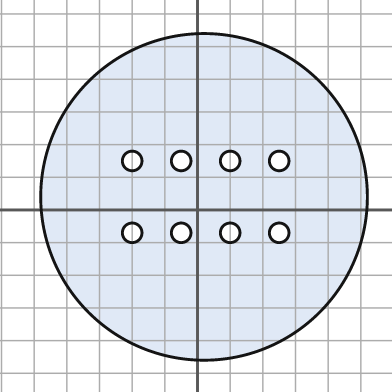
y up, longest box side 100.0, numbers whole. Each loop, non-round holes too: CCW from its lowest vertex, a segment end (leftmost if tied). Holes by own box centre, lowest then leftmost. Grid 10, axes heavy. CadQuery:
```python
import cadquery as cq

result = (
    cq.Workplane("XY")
    .moveTo(2.0, 4.0)
    .circle(50.0)
    .moveTo(-20.0, -7.0)
    .circle(3.0)
    .moveTo(-5.0, -7.0)
    .circle(3.0)
    .moveTo(10.0, -7.0)
    .circle(3.0)
    .moveTo(25.0, -7.0)
    .circle(3.0)
    .moveTo(-20.0, 15.0)
    .circle(3.0)
    .moveTo(-5.0, 15.0)
    .circle(3.0)
    .moveTo(10.0, 15.0)
    .circle(3.0)
    .moveTo(25.0, 15.0)
    .circle(3.0)
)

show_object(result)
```